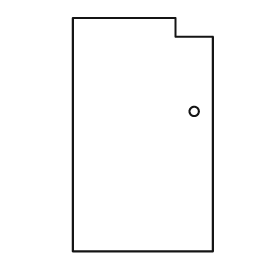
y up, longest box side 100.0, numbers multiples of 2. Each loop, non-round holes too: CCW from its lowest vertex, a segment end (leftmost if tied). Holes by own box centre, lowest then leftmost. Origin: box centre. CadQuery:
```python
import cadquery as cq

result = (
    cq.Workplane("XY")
    .moveTo(-30.0, -50.0)
    .lineTo(30.0, -50.0)
    .lineTo(30.0, 42.0)
    .lineTo(14.0, 42.0)
    .lineTo(14.0, 50.0)
    .lineTo(-30.0, 50.0)
    .close()
    .moveTo(22.0, 10.0)
    .circle(2.0)
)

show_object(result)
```